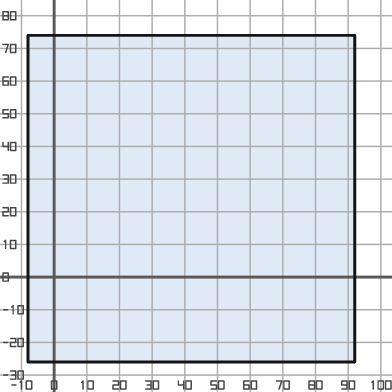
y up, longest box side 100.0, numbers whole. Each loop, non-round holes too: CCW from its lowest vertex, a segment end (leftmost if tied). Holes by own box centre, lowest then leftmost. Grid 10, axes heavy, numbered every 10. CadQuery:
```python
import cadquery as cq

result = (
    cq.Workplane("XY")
    .moveTo(-8.0, -26.0)
    .lineTo(92.0, -26.0)
    .lineTo(92.0, 74.0)
    .lineTo(-8.0, 74.0)
    .close()
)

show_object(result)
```